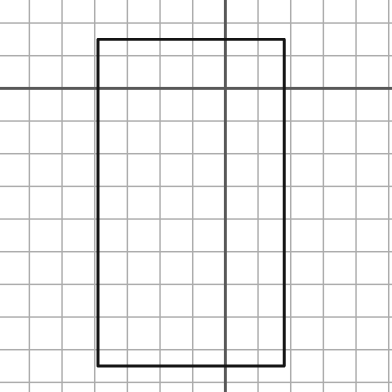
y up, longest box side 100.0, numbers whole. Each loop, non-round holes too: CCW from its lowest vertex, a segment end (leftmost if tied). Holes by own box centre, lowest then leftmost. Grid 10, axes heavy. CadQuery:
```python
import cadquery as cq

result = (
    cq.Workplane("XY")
    .moveTo(-39.0, -85.0)
    .lineTo(18.0, -85.0)
    .lineTo(18.0, 15.0)
    .lineTo(-39.0, 15.0)
    .close()
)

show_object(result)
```